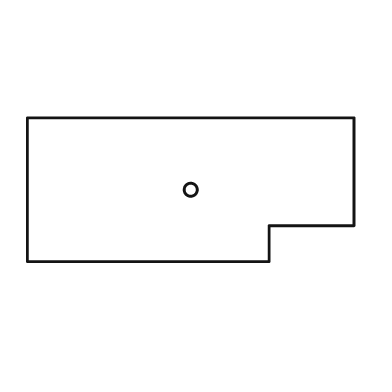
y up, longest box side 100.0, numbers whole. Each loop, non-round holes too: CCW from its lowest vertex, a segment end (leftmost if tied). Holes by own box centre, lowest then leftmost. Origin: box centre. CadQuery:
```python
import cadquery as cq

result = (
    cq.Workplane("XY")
    .moveTo(-50.0, -22.0)
    .lineTo(24.0, -22.0)
    .lineTo(24.0, -11.0)
    .lineTo(50.0, -11.0)
    .lineTo(50.0, 22.0)
    .lineTo(-50.0, 22.0)
    .close()
    .moveTo(0.0, 0.0)
    .circle(2.0)
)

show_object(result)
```